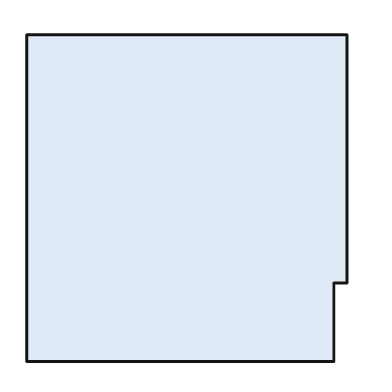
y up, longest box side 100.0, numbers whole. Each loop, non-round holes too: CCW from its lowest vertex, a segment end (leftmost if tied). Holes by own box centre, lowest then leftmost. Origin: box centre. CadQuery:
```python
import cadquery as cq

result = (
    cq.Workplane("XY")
    .moveTo(-49.0, -50.0)
    .lineTo(45.0, -50.0)
    .lineTo(45.0, -26.0)
    .lineTo(49.0, -26.0)
    .lineTo(49.0, 50.0)
    .lineTo(-49.0, 50.0)
    .close()
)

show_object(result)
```